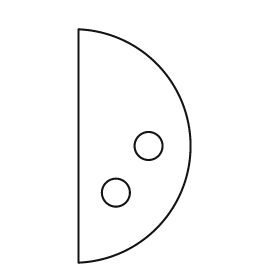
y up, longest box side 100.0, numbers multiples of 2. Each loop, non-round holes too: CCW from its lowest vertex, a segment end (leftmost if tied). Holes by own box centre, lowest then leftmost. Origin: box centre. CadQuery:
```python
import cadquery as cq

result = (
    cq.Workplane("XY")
    .moveTo(-24.0, -50.0)
    .threePointArc((24.0, 0.0), (-24.0, 50.0))
    .close()
    .moveTo(-8.0, -20.0)
    .circle(6.0)
    .moveTo(6.0, 0.0)
    .circle(6.0)
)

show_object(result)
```